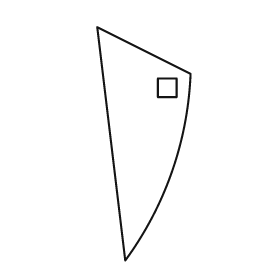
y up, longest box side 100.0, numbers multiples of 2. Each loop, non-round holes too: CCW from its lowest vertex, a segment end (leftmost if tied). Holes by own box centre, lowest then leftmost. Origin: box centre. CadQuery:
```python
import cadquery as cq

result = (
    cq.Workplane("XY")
    .moveTo(-8.0, -50.0)
    .threePointArc((12.0, -12.0), (20.0, 30.0))
    .lineTo(-20.0, 50.0)
    .close()
    .moveTo(6.0, 20.0)
    .lineTo(14.0, 20.0)
    .lineTo(14.0, 28.0)
    .lineTo(6.0, 28.0)
    .close()
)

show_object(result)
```